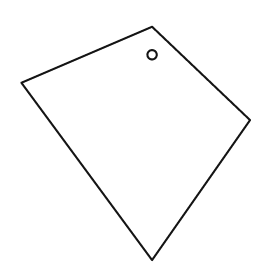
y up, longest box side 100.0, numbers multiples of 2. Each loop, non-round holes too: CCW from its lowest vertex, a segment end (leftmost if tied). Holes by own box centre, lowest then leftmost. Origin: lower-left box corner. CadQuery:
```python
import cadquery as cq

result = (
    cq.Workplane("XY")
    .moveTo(56.0, 0.0)
    .lineTo(98.0, 60.0)
    .lineTo(56.0, 100.0)
    .lineTo(0.0, 76.0)
    .close()
    .moveTo(56.0, 88.0)
    .circle(2.0)
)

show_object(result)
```